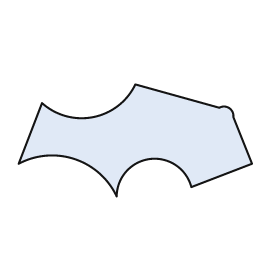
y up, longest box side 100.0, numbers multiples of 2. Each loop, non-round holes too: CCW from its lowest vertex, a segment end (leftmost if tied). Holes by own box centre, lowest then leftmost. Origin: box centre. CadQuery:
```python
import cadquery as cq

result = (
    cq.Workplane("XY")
    .moveTo(-8.0, -24.0)
    .threePointArc((6.0, -8.0), (24.0, -20.0))
    .lineTo(50.0, -10.0)
    .lineTo(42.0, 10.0)
    .threePointArc((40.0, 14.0), (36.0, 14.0))
    .lineTo(0.0, 24.0)
    .threePointArc((-18.0, 10.0), (-40.0, 16.0))
    .lineTo(-50.0, -10.0)
    .threePointArc((-26.0, -8.0), (-8.0, -24.0))
    .close()
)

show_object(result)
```